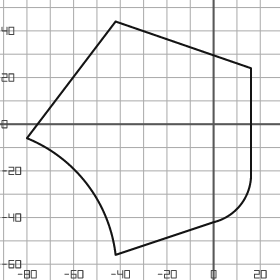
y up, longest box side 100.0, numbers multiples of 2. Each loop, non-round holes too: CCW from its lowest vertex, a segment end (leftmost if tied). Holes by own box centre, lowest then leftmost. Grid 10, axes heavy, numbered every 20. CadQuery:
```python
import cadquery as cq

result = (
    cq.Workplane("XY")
    .moveTo(-42.0, -56.0)
    .lineTo(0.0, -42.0)
    .threePointArc((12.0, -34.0), (16.0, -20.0))
    .lineTo(16.0, 24.0)
    .lineTo(-42.0, 44.0)
    .lineTo(-80.0, -6.0)
    .threePointArc((-54.0, -26.0), (-42.0, -56.0))
    .close()
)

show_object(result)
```